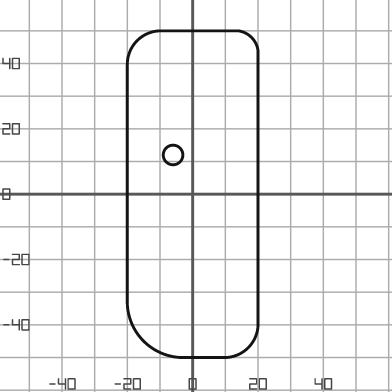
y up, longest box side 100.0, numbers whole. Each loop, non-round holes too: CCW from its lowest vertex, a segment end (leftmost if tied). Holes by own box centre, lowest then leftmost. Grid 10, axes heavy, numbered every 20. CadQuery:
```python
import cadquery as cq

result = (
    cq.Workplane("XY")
    .moveTo(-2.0, -50.0)
    .lineTo(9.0, -50.0)
    .threePointArc((17.0, -47.0), (20.0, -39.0))
    .lineTo(20.0, 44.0)
    .threePointArc((18.0, 48.0), (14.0, 50.0))
    .lineTo(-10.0, 50.0)
    .threePointArc((-17.0, 47.0), (-20.0, 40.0))
    .lineTo(-20.0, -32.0)
    .threePointArc((-15.0, -45.0), (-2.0, -50.0))
    .close()
    .moveTo(-6.0, 12.0)
    .circle(3.0)
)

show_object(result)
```